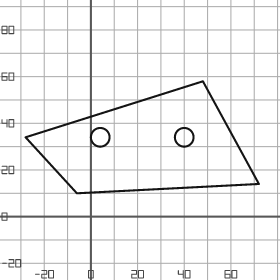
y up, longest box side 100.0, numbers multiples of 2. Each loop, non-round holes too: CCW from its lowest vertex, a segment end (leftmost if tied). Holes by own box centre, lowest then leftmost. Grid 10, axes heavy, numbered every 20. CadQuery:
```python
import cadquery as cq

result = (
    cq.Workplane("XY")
    .moveTo(-6.0, 10.0)
    .lineTo(72.0, 14.0)
    .lineTo(48.0, 58.0)
    .lineTo(-28.0, 34.0)
    .close()
    .moveTo(4.0, 34.0)
    .circle(4.0)
    .moveTo(40.0, 34.0)
    .circle(4.0)
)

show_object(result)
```